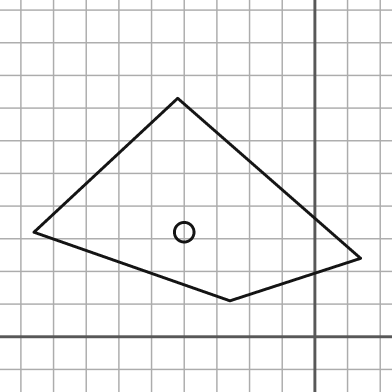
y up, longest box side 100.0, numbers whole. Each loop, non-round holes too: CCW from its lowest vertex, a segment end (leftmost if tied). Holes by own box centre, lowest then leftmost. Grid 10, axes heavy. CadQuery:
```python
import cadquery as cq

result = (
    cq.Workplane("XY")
    .moveTo(-26.0, 11.0)
    .lineTo(14.0, 24.0)
    .lineTo(-42.0, 73.0)
    .lineTo(-86.0, 32.0)
    .close()
    .moveTo(-40.0, 32.0)
    .circle(3.0)
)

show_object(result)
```